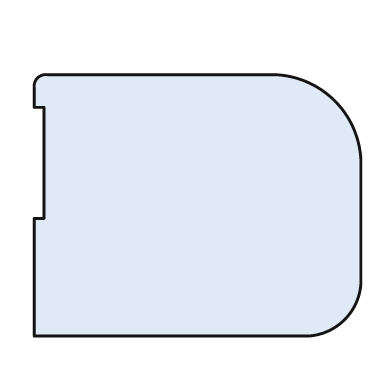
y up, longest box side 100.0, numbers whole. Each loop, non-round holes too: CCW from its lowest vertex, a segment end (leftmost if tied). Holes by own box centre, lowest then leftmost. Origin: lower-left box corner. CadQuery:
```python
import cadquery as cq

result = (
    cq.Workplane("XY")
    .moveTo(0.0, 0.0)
    .lineTo(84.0, 0.0)
    .threePointArc((95.0, 5.0), (100.0, 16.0))
    .lineTo(100.0, 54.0)
    .threePointArc((92.0, 72.0), (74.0, 80.0))
    .lineTo(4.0, 80.0)
    .threePointArc((1.0, 79.0), (0.0, 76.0))
    .lineTo(0.0, 70.0)
    .lineTo(3.0, 70.0)
    .lineTo(3.0, 36.0)
    .lineTo(0.0, 36.0)
    .close()
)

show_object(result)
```